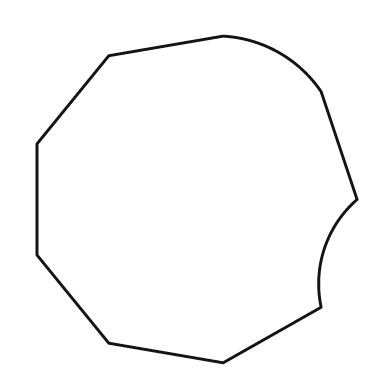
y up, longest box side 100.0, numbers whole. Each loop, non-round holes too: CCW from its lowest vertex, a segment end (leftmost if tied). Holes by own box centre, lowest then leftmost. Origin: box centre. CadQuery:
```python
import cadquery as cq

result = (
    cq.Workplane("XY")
    .moveTo(8.0, -50.0)
    .lineTo(38.0, -33.0)
    .threePointArc((39.0, -15.0), (49.0, 0.0))
    .lineTo(38.0, 33.0)
    .threePointArc((25.0, 45.0), (8.0, 50.0))
    .lineTo(-27.0, 44.0)
    .lineTo(-49.0, 17.0)
    .lineTo(-49.0, -17.0)
    .lineTo(-27.0, -44.0)
    .close()
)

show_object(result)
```